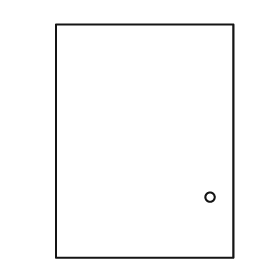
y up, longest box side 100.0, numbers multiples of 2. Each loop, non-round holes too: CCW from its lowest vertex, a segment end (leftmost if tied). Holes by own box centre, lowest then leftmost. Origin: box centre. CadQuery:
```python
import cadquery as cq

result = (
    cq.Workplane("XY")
    .moveTo(-38.0, -50.0)
    .lineTo(38.0, -50.0)
    .lineTo(38.0, 50.0)
    .lineTo(-38.0, 50.0)
    .close()
    .moveTo(28.0, -24.0)
    .circle(2.0)
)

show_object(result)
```